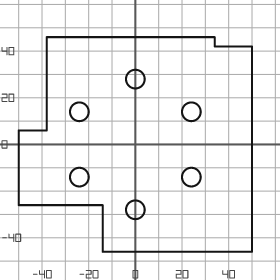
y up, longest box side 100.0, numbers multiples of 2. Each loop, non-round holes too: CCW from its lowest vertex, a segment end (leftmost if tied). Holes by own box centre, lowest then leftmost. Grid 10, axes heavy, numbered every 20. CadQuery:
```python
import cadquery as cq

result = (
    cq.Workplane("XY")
    .moveTo(-14.0, -46.0)
    .lineTo(50.0, -46.0)
    .lineTo(50.0, 42.0)
    .lineTo(34.0, 42.0)
    .lineTo(34.0, 46.0)
    .lineTo(-38.0, 46.0)
    .lineTo(-38.0, 6.0)
    .lineTo(-50.0, 6.0)
    .lineTo(-50.0, -26.0)
    .lineTo(-14.0, -26.0)
    .close()
    .moveTo(0.0, -28.0)
    .circle(4.0)
    .moveTo(-24.0, -14.0)
    .circle(4.0)
    .moveTo(24.0, -14.0)
    .circle(4.0)
    .moveTo(-24.0, 14.0)
    .circle(4.0)
    .moveTo(24.0, 14.0)
    .circle(4.0)
    .moveTo(0.0, 28.0)
    .circle(4.0)
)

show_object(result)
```